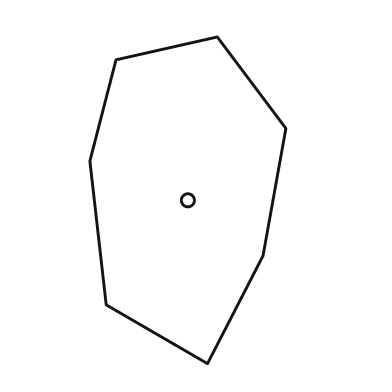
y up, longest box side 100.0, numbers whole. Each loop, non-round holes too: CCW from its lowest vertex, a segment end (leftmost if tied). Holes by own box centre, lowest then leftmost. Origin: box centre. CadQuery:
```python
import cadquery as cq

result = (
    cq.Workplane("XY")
    .moveTo(6.0, -50.0)
    .lineTo(23.0, -17.0)
    .lineTo(30.0, 22.0)
    .lineTo(9.0, 50.0)
    .lineTo(-22.0, 43.0)
    .lineTo(-30.0, 12.0)
    .lineTo(-25.0, -32.0)
    .close()
    .moveTo(0.0, 0.0)
    .circle(2.0)
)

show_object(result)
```